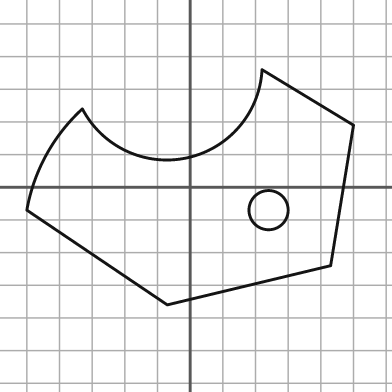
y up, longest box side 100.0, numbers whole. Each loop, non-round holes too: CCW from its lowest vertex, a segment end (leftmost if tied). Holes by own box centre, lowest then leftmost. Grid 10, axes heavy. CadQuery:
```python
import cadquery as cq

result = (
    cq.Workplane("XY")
    .moveTo(-7.0, -36.0)
    .lineTo(43.0, -24.0)
    .lineTo(50.0, 19.0)
    .lineTo(22.0, 36.0)
    .threePointArc((-1.0, 9.0), (-33.0, 24.0))
    .threePointArc((-44.0, 10.0), (-50.0, -7.0))
    .close()
    .moveTo(24.0, -7.0)
    .circle(6.0)
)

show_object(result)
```